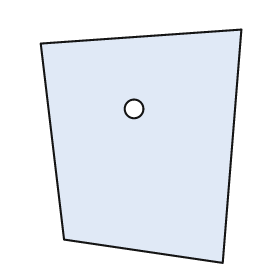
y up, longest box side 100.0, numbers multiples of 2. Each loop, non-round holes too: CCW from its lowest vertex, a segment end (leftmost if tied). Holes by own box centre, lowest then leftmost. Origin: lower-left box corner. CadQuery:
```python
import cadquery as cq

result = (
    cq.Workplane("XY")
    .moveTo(78.0, 0.0)
    .lineTo(86.0, 100.0)
    .lineTo(0.0, 94.0)
    .lineTo(10.0, 10.0)
    .close()
    .moveTo(40.0, 66.0)
    .circle(4.0)
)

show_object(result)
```